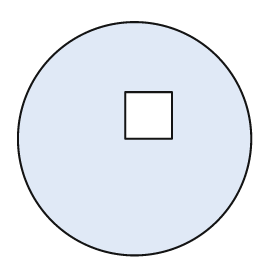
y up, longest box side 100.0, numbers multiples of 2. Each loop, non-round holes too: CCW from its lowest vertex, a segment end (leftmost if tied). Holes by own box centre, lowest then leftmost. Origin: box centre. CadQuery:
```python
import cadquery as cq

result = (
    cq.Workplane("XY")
    .moveTo(0.0, 0.0)
    .circle(50.0)
    .moveTo(-4.0, 0.0)
    .lineTo(16.0, 0.0)
    .lineTo(16.0, 20.0)
    .lineTo(-4.0, 20.0)
    .close()
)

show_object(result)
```